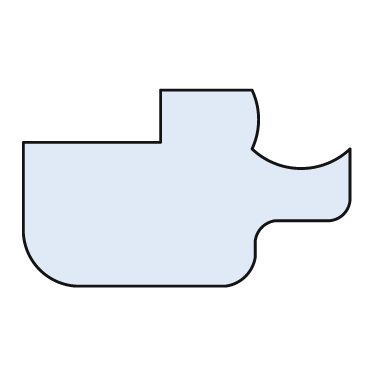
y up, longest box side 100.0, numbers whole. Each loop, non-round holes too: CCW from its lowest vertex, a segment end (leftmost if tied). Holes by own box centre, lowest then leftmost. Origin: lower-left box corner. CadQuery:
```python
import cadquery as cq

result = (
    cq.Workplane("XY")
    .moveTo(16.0, 0.0)
    .lineTo(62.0, 0.0)
    .threePointArc((68.0, 3.0), (71.0, 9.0))
    .lineTo(71.0, 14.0)
    .threePointArc((73.0, 18.0), (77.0, 20.0))
    .lineTo(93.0, 20.0)
    .threePointArc((98.0, 22.0), (100.0, 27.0))
    .lineTo(100.0, 42.0)
    .threePointArc((85.0, 36.0), (70.0, 42.0))
    .threePointArc((72.0, 51.0), (70.0, 60.0))
    .lineTo(42.0, 60.0)
    .lineTo(42.0, 44.0)
    .lineTo(0.0, 44.0)
    .lineTo(0.0, 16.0)
    .threePointArc((5.0, 5.0), (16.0, 0.0))
    .close()
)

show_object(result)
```